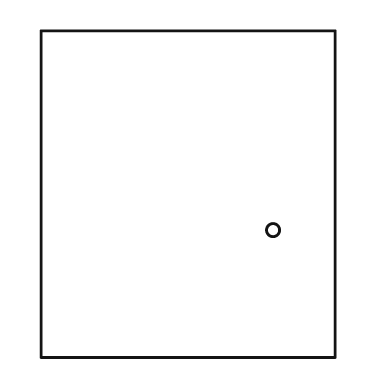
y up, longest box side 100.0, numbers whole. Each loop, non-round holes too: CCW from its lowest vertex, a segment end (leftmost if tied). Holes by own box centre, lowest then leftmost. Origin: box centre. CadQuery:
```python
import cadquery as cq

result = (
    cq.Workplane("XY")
    .moveTo(-45.0, -50.0)
    .lineTo(45.0, -50.0)
    .lineTo(45.0, 50.0)
    .lineTo(-45.0, 50.0)
    .close()
    .moveTo(26.0, -11.0)
    .circle(2.0)
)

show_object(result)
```